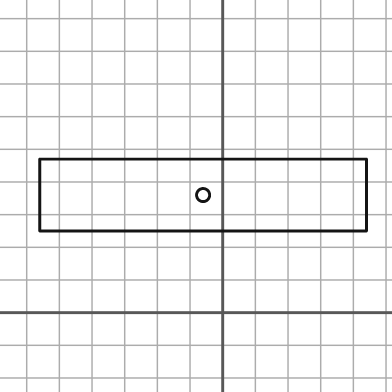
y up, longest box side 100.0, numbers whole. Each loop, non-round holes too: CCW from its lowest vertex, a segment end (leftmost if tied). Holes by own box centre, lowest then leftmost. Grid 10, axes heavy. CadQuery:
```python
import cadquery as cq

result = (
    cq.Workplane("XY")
    .moveTo(-56.0, 25.0)
    .lineTo(44.0, 25.0)
    .lineTo(44.0, 47.0)
    .lineTo(-56.0, 47.0)
    .close()
    .moveTo(-6.0, 36.0)
    .circle(2.0)
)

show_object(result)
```